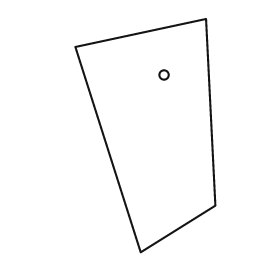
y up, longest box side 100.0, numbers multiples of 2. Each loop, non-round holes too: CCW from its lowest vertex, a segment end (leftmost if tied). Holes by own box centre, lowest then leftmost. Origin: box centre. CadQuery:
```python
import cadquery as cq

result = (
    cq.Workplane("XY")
    .moveTo(-2.0, -50.0)
    .lineTo(30.0, -30.0)
    .lineTo(26.0, 50.0)
    .lineTo(-30.0, 38.0)
    .close()
    .moveTo(8.0, 26.0)
    .circle(2.0)
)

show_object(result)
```